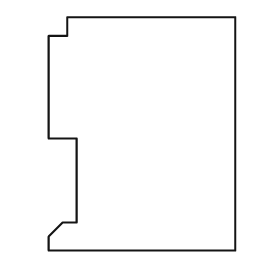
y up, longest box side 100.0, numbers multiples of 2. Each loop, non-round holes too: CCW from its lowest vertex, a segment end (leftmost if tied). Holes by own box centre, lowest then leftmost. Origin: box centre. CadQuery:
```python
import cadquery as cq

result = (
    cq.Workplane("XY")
    .moveTo(-40.0, -50.0)
    .lineTo(40.0, -50.0)
    .lineTo(40.0, 50.0)
    .lineTo(-32.0, 50.0)
    .lineTo(-32.0, 42.0)
    .lineTo(-40.0, 42.0)
    .lineTo(-40.0, -2.0)
    .lineTo(-28.0, -2.0)
    .lineTo(-28.0, -38.0)
    .lineTo(-34.0, -38.0)
    .lineTo(-40.0, -44.0)
    .close()
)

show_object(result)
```